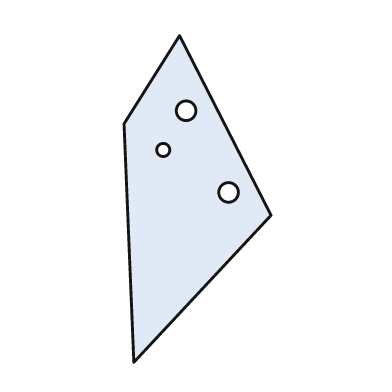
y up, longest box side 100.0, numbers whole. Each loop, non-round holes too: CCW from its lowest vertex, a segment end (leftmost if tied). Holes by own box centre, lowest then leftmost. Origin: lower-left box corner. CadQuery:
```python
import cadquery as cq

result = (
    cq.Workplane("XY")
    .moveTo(3.0, 0.0)
    .lineTo(45.0, 45.0)
    .lineTo(17.0, 100.0)
    .lineTo(0.0, 73.0)
    .close()
    .moveTo(32.0, 52.0)
    .circle(3.0)
    .moveTo(12.0, 65.0)
    .circle(2.0)
    .moveTo(19.0, 77.0)
    .circle(3.0)
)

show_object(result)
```